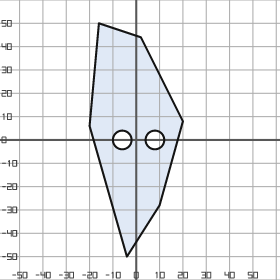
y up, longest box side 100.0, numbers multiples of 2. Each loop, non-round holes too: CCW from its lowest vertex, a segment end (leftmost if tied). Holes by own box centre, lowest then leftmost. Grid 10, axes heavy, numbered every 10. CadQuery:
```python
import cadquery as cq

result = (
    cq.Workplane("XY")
    .moveTo(-4.0, -50.0)
    .lineTo(10.0, -28.0)
    .lineTo(20.0, 8.0)
    .lineTo(2.0, 44.0)
    .lineTo(-16.0, 50.0)
    .lineTo(-20.0, 6.0)
    .close()
    .moveTo(-6.0, 0.0)
    .circle(4.0)
    .moveTo(8.0, 0.0)
    .circle(4.0)
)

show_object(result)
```